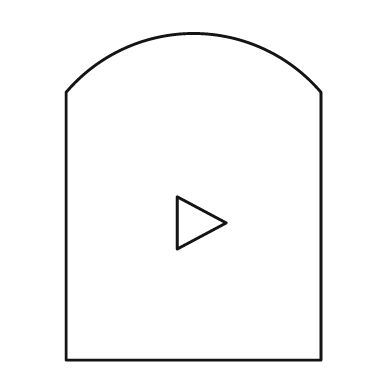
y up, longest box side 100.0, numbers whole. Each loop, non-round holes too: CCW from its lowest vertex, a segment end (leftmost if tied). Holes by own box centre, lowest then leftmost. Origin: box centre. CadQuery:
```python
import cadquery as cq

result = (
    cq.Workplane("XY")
    .moveTo(-39.0, -50.0)
    .lineTo(39.0, -50.0)
    .lineTo(39.0, 32.0)
    .threePointArc((0.0, 50.0), (-39.0, 32.0))
    .close()
    .moveTo(-5.0, -16.0)
    .lineTo(10.0, -8.0)
    .lineTo(-5.0, 0.0)
    .close()
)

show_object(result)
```